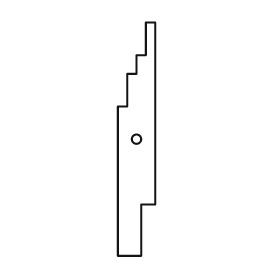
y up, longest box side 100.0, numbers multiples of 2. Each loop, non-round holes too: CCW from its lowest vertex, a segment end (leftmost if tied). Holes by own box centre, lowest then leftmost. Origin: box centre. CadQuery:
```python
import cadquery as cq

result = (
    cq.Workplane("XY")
    .moveTo(-8.0, -50.0)
    .lineTo(2.0, -50.0)
    .lineTo(2.0, -28.0)
    .lineTo(8.0, -28.0)
    .lineTo(8.0, 50.0)
    .lineTo(4.0, 50.0)
    .lineTo(4.0, 36.0)
    .lineTo(0.0, 36.0)
    .lineTo(0.0, 28.0)
    .lineTo(-4.0, 28.0)
    .lineTo(-4.0, 14.0)
    .lineTo(-8.0, 14.0)
    .close()
    .moveTo(0.0, 0.0)
    .circle(2.0)
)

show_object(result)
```